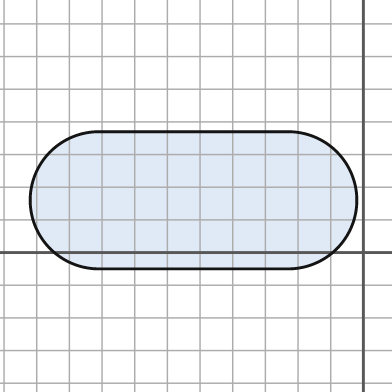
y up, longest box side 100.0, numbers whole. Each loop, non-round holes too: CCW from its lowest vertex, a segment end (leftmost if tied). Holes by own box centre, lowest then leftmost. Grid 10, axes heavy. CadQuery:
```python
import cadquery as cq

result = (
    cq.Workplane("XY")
    .moveTo(-81.0, -5.0)
    .lineTo(-23.0, -5.0)
    .threePointArc((-2.0, 16.0), (-23.0, 37.0))
    .lineTo(-81.0, 37.0)
    .threePointArc((-102.0, 16.0), (-81.0, -5.0))
    .close()
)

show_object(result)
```